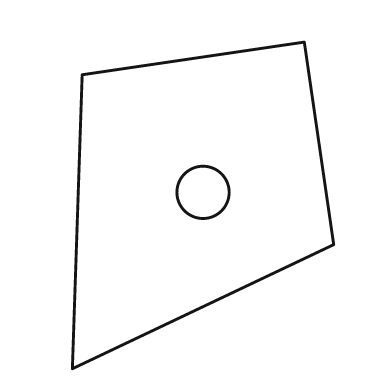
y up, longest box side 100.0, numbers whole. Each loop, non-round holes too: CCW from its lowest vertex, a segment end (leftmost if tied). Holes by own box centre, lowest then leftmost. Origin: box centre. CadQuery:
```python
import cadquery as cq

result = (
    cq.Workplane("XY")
    .moveTo(-40.0, -50.0)
    .lineTo(40.0, -12.0)
    .lineTo(31.0, 50.0)
    .lineTo(-37.0, 40.0)
    .close()
    .moveTo(0.0, 4.0)
    .circle(8.0)
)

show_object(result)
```